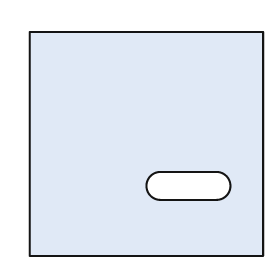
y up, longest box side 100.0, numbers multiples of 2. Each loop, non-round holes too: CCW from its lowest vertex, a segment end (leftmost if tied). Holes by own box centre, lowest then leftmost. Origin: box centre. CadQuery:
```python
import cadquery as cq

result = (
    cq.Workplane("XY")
    .moveTo(-50.0, -48.0)
    .lineTo(50.0, -48.0)
    .lineTo(50.0, 48.0)
    .lineTo(-50.0, 48.0)
    .close()
    .moveTo(6.0, -24.0)
    .lineTo(30.0, -24.0)
    .threePointArc((36.0, -18.0), (30.0, -12.0))
    .lineTo(6.0, -12.0)
    .threePointArc((0.0, -18.0), (6.0, -24.0))
    .close()
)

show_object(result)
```